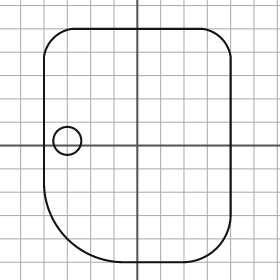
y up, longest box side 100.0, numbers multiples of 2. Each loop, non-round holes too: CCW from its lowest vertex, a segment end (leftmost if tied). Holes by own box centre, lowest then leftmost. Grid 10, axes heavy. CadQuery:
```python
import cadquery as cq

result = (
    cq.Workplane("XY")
    .moveTo(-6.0, -50.0)
    .lineTo(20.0, -50.0)
    .threePointArc((34.0, -44.0), (40.0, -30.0))
    .lineTo(40.0, 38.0)
    .threePointArc((36.0, 46.0), (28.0, 50.0))
    .lineTo(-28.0, 50.0)
    .threePointArc((-36.0, 46.0), (-40.0, 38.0))
    .lineTo(-40.0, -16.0)
    .threePointArc((-30.0, -40.0), (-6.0, -50.0))
    .close()
    .moveTo(-30.0, 2.0)
    .circle(6.0)
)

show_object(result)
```